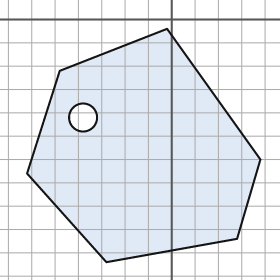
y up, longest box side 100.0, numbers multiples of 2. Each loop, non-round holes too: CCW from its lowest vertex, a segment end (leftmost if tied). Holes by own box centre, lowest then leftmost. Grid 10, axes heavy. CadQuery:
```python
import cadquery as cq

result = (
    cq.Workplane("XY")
    .moveTo(-28.0, -104.0)
    .lineTo(28.0, -94.0)
    .lineTo(38.0, -60.0)
    .lineTo(-2.0, -4.0)
    .lineTo(-48.0, -22.0)
    .lineTo(-62.0, -66.0)
    .close()
    .moveTo(-38.0, -42.0)
    .circle(6.0)
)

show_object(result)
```